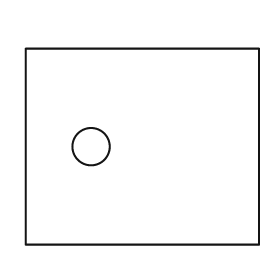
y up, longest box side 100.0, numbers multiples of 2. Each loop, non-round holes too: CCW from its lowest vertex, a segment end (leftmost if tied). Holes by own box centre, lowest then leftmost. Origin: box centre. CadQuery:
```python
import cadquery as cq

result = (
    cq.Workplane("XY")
    .moveTo(-50.0, -42.0)
    .lineTo(50.0, -42.0)
    .lineTo(50.0, 42.0)
    .lineTo(-50.0, 42.0)
    .close()
    .moveTo(-22.0, 0.0)
    .circle(8.0)
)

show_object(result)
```